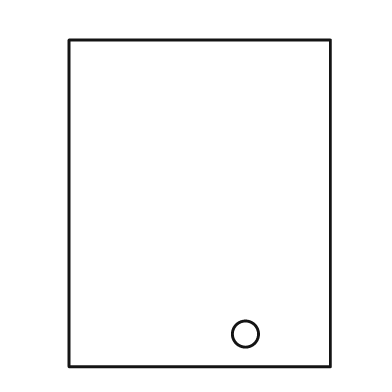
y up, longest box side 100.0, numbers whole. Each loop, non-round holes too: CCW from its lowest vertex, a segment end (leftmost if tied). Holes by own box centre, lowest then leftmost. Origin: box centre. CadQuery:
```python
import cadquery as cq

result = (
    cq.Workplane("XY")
    .moveTo(-40.0, -50.0)
    .lineTo(40.0, -50.0)
    .lineTo(40.0, 50.0)
    .lineTo(-40.0, 50.0)
    .close()
    .moveTo(14.0, -40.0)
    .circle(4.0)
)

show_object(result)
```